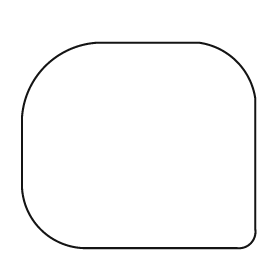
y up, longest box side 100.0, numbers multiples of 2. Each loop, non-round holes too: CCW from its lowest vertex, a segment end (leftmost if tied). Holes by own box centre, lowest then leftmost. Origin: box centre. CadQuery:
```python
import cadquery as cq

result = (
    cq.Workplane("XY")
    .moveTo(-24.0, -44.0)
    .lineTo(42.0, -44.0)
    .threePointArc((48.0, -42.0), (50.0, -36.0))
    .lineTo(50.0, 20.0)
    .threePointArc((42.0, 36.0), (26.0, 44.0))
    .lineTo(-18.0, 44.0)
    .threePointArc((-40.0, 34.0), (-50.0, 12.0))
    .lineTo(-50.0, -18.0)
    .threePointArc((-42.0, -36.0), (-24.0, -44.0))
    .close()
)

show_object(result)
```